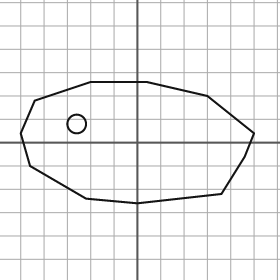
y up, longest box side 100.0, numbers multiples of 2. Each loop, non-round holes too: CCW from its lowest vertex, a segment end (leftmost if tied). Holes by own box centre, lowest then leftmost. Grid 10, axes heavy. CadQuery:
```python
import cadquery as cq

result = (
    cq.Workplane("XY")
    .moveTo(0.0, -26.0)
    .lineTo(36.0, -22.0)
    .lineTo(46.0, -6.0)
    .lineTo(50.0, 4.0)
    .lineTo(30.0, 20.0)
    .lineTo(4.0, 26.0)
    .lineTo(-20.0, 26.0)
    .lineTo(-44.0, 18.0)
    .lineTo(-50.0, 4.0)
    .lineTo(-46.0, -10.0)
    .lineTo(-22.0, -24.0)
    .close()
    .moveTo(-26.0, 8.0)
    .circle(4.0)
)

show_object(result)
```